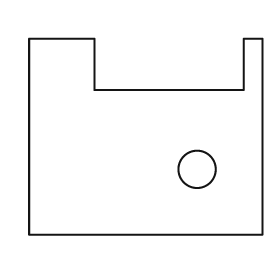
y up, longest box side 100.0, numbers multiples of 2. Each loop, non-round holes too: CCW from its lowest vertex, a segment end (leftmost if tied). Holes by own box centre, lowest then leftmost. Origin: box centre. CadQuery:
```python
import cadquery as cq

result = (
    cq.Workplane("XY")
    .moveTo(-50.0, -42.0)
    .lineTo(50.0, -42.0)
    .lineTo(50.0, 42.0)
    .lineTo(42.0, 42.0)
    .lineTo(42.0, 20.0)
    .lineTo(-22.0, 20.0)
    .lineTo(-22.0, 42.0)
    .lineTo(-50.0, 42.0)
    .close()
    .moveTo(22.0, -14.0)
    .circle(8.0)
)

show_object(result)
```